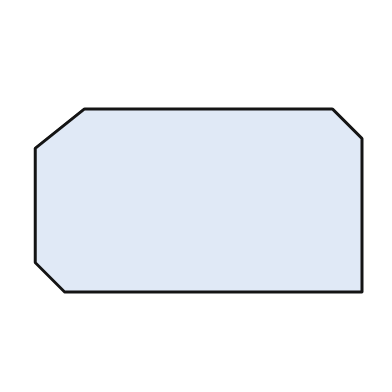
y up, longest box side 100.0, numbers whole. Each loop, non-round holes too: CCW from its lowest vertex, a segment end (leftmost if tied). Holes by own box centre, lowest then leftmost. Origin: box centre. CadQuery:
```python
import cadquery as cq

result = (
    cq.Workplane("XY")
    .moveTo(-41.0, -28.0)
    .lineTo(50.0, -28.0)
    .lineTo(50.0, 19.0)
    .lineTo(41.0, 28.0)
    .lineTo(-35.0, 28.0)
    .lineTo(-50.0, 16.0)
    .lineTo(-50.0, -19.0)
    .close()
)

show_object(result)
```